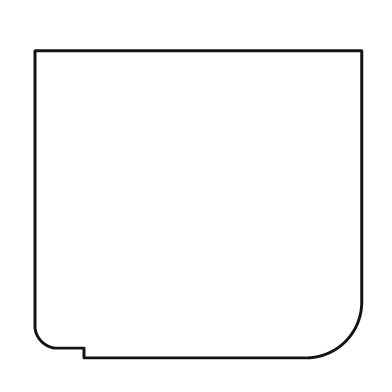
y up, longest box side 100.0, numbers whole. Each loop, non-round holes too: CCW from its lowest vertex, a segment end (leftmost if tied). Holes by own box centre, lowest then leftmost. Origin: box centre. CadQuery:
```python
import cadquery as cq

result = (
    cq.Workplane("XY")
    .moveTo(-35.0, -47.0)
    .lineTo(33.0, -47.0)
    .threePointArc((45.0, -42.0), (50.0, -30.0))
    .lineTo(50.0, 47.0)
    .lineTo(-50.0, 47.0)
    .lineTo(-50.0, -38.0)
    .threePointArc((-48.0, -42.0), (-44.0, -44.0))
    .lineTo(-35.0, -44.0)
    .close()
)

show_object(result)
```